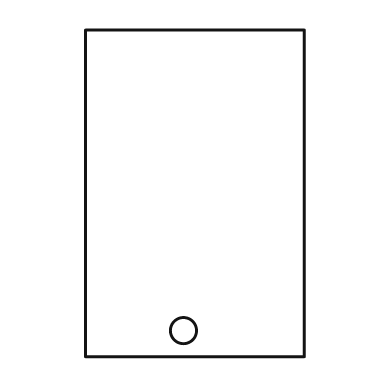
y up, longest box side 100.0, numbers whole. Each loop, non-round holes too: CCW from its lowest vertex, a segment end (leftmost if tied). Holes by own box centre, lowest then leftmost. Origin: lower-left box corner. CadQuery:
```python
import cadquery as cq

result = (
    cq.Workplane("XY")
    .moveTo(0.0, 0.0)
    .lineTo(67.0, 0.0)
    .lineTo(67.0, 100.0)
    .lineTo(0.0, 100.0)
    .close()
    .moveTo(30.0, 8.0)
    .circle(4.0)
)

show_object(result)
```